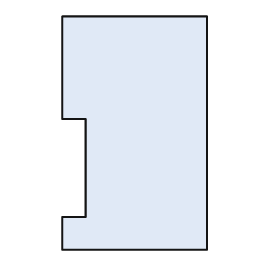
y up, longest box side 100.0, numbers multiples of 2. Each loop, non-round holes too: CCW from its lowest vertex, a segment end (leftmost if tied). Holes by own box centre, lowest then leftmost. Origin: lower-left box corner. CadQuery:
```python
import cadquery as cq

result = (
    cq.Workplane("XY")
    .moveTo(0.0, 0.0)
    .lineTo(62.0, 0.0)
    .lineTo(62.0, 100.0)
    .lineTo(0.0, 100.0)
    .lineTo(0.0, 56.0)
    .lineTo(10.0, 56.0)
    .lineTo(10.0, 14.0)
    .lineTo(0.0, 14.0)
    .close()
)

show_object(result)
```